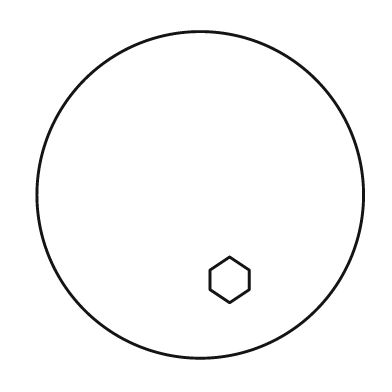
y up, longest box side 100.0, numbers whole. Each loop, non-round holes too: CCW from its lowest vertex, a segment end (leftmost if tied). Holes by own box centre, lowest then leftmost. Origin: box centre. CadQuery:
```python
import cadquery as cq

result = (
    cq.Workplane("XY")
    .moveTo(0.0, 0.0)
    .circle(50.0)
    .moveTo(9.0, -33.0)
    .lineTo(15.0, -29.0)
    .lineTo(15.0, -23.0)
    .lineTo(9.0, -19.0)
    .lineTo(3.0, -23.0)
    .lineTo(3.0, -29.0)
    .close()
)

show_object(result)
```